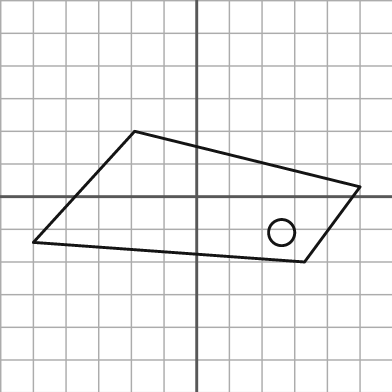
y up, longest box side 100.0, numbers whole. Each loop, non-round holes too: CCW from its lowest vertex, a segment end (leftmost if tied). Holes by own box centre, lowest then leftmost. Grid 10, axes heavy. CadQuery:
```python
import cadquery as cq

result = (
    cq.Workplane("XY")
    .moveTo(33.0, -20.0)
    .lineTo(50.0, 3.0)
    .lineTo(-19.0, 20.0)
    .lineTo(-50.0, -14.0)
    .close()
    .moveTo(26.0, -11.0)
    .circle(4.0)
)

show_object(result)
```